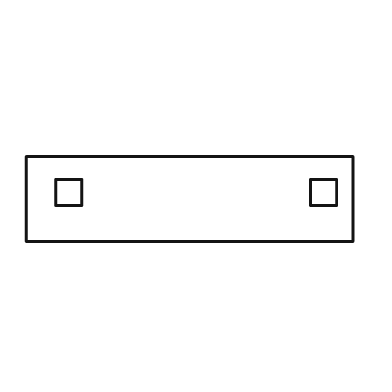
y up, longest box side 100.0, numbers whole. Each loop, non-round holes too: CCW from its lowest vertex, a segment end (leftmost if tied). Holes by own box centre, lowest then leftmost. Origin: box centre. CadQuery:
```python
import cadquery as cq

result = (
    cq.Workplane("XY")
    .moveTo(-50.0, -13.0)
    .lineTo(50.0, -13.0)
    .lineTo(50.0, 13.0)
    .lineTo(-50.0, 13.0)
    .close()
    .moveTo(-41.0, -2.0)
    .lineTo(-33.0, -2.0)
    .lineTo(-33.0, 6.0)
    .lineTo(-41.0, 6.0)
    .close()
    .moveTo(37.0, -2.0)
    .lineTo(45.0, -2.0)
    .lineTo(45.0, 6.0)
    .lineTo(37.0, 6.0)
    .close()
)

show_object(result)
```